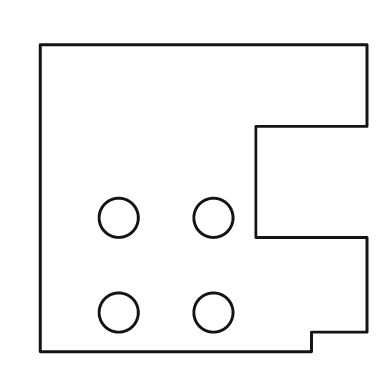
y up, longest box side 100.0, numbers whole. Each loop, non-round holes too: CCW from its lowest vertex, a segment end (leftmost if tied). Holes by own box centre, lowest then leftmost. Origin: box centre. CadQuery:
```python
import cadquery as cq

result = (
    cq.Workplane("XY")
    .moveTo(-50.0, -47.0)
    .lineTo(33.0, -47.0)
    .lineTo(33.0, -41.0)
    .lineTo(50.0, -41.0)
    .lineTo(50.0, -12.0)
    .lineTo(16.0, -12.0)
    .lineTo(16.0, 22.0)
    .lineTo(50.0, 22.0)
    .lineTo(50.0, 47.0)
    .lineTo(-50.0, 47.0)
    .close()
    .moveTo(-26.0, -35.0)
    .circle(6.0)
    .moveTo(3.0, -35.0)
    .circle(6.0)
    .moveTo(-26.0, -6.0)
    .circle(6.0)
    .moveTo(3.0, -6.0)
    .circle(6.0)
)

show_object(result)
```